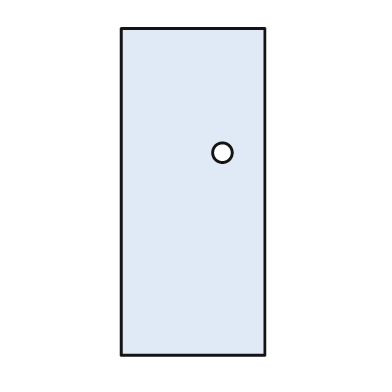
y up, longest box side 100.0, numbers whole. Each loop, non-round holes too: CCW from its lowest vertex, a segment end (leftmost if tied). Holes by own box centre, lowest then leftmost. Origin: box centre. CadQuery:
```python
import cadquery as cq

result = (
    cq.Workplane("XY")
    .moveTo(-22.0, -50.0)
    .lineTo(22.0, -50.0)
    .lineTo(22.0, 50.0)
    .lineTo(-22.0, 50.0)
    .close()
    .moveTo(9.0, 12.0)
    .circle(3.0)
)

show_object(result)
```